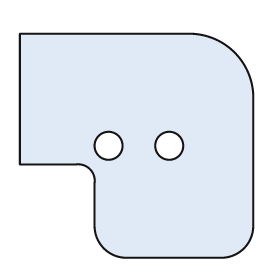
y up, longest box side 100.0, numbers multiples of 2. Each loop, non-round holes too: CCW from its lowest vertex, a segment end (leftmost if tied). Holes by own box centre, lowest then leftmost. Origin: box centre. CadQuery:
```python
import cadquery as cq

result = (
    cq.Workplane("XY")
    .moveTo(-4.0, -48.0)
    .lineTo(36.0, -48.0)
    .threePointArc((46.0, -44.0), (50.0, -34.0))
    .lineTo(50.0, 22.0)
    .threePointArc((42.0, 40.0), (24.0, 48.0))
    .lineTo(-50.0, 48.0)
    .lineTo(-50.0, -8.0)
    .lineTo(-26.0, -8.0)
    .threePointArc((-20.0, -10.0), (-18.0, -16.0))
    .lineTo(-18.0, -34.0)
    .threePointArc((-14.0, -44.0), (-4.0, -48.0))
    .close()
    .moveTo(-12.0, 0.0)
    .circle(6.0)
    .moveTo(14.0, 0.0)
    .circle(6.0)
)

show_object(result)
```